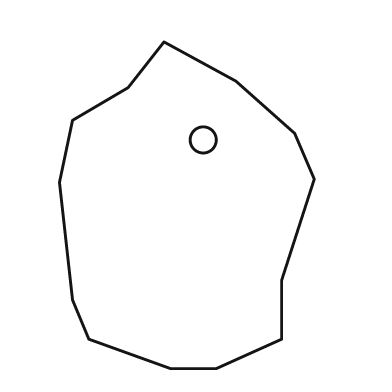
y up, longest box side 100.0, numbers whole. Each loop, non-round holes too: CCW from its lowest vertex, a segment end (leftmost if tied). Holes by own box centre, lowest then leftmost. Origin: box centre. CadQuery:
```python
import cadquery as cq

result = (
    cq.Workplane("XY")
    .moveTo(-5.0, -50.0)
    .lineTo(9.0, -50.0)
    .lineTo(29.0, -41.0)
    .lineTo(29.0, -23.0)
    .lineTo(39.0, 8.0)
    .lineTo(33.0, 22.0)
    .lineTo(15.0, 38.0)
    .lineTo(-7.0, 50.0)
    .lineTo(-18.0, 36.0)
    .lineTo(-35.0, 26.0)
    .lineTo(-39.0, 7.0)
    .lineTo(-35.0, -29.0)
    .lineTo(-30.0, -41.0)
    .close()
    .moveTo(5.0, 20.0)
    .circle(4.0)
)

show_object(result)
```